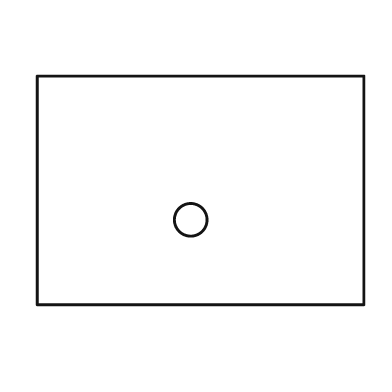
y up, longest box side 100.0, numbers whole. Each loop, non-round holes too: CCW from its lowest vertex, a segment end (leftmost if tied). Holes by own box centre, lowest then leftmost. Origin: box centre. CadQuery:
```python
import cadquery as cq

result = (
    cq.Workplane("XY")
    .moveTo(-50.0, -35.0)
    .lineTo(50.0, -35.0)
    .lineTo(50.0, 35.0)
    .lineTo(-50.0, 35.0)
    .close()
    .moveTo(-3.0, -9.0)
    .circle(5.0)
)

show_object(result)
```